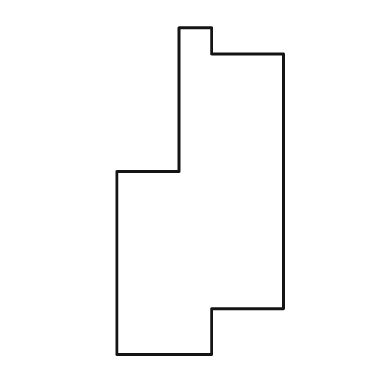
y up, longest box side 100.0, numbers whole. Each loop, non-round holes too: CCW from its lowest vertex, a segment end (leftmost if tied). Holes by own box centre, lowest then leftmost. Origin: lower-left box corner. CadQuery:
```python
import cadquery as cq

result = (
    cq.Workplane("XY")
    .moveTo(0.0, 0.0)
    .lineTo(29.0, 0.0)
    .lineTo(29.0, 14.0)
    .lineTo(51.0, 14.0)
    .lineTo(51.0, 92.0)
    .lineTo(29.0, 92.0)
    .lineTo(29.0, 100.0)
    .lineTo(19.0, 100.0)
    .lineTo(19.0, 56.0)
    .lineTo(0.0, 56.0)
    .close()
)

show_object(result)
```